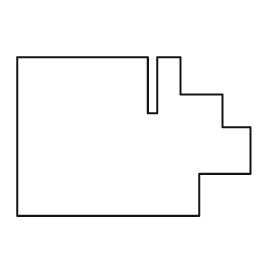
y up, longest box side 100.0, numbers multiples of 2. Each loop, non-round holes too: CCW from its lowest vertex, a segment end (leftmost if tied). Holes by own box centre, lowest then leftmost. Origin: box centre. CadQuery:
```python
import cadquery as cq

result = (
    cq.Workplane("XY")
    .moveTo(-50.0, -34.0)
    .lineTo(28.0, -34.0)
    .lineTo(28.0, -16.0)
    .lineTo(50.0, -16.0)
    .lineTo(50.0, 4.0)
    .lineTo(38.0, 4.0)
    .lineTo(38.0, 18.0)
    .lineTo(20.0, 18.0)
    .lineTo(20.0, 34.0)
    .lineTo(10.0, 34.0)
    .lineTo(10.0, 10.0)
    .lineTo(6.0, 10.0)
    .lineTo(6.0, 34.0)
    .lineTo(-50.0, 34.0)
    .close()
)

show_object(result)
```